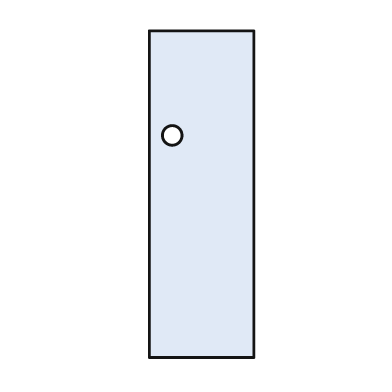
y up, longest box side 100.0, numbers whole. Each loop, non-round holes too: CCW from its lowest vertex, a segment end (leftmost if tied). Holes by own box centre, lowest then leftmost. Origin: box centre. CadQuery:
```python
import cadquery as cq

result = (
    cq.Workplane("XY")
    .moveTo(-16.0, -50.0)
    .lineTo(16.0, -50.0)
    .lineTo(16.0, 50.0)
    .lineTo(-16.0, 50.0)
    .close()
    .moveTo(-9.0, 18.0)
    .circle(3.0)
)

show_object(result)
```